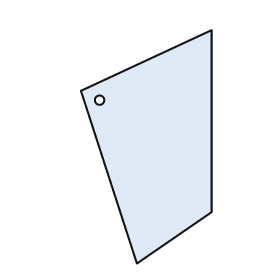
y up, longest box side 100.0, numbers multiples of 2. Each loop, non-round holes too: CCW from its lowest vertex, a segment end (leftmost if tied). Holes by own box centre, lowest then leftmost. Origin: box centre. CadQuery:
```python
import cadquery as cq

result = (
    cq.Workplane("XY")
    .moveTo(-4.0, -50.0)
    .lineTo(28.0, -28.0)
    .lineTo(28.0, 50.0)
    .lineTo(-28.0, 24.0)
    .close()
    .moveTo(-20.0, 20.0)
    .circle(2.0)
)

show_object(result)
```